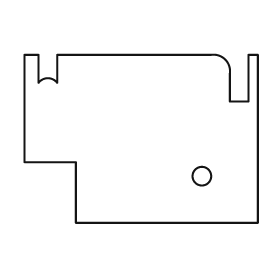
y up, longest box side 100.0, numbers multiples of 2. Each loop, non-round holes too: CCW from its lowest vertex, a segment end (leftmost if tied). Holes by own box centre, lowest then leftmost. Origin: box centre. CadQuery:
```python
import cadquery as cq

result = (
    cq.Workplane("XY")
    .moveTo(-28.0, -36.0)
    .lineTo(50.0, -36.0)
    .lineTo(50.0, 36.0)
    .lineTo(46.0, 36.0)
    .lineTo(46.0, 16.0)
    .lineTo(38.0, 16.0)
    .lineTo(38.0, 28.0)
    .threePointArc((36.0, 34.0), (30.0, 36.0))
    .lineTo(-36.0, 36.0)
    .lineTo(-36.0, 24.0)
    .threePointArc((-40.0, 26.0), (-44.0, 24.0))
    .lineTo(-44.0, 36.0)
    .lineTo(-50.0, 36.0)
    .lineTo(-50.0, -10.0)
    .lineTo(-28.0, -10.0)
    .close()
    .moveTo(26.0, -16.0)
    .circle(4.0)
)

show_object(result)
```